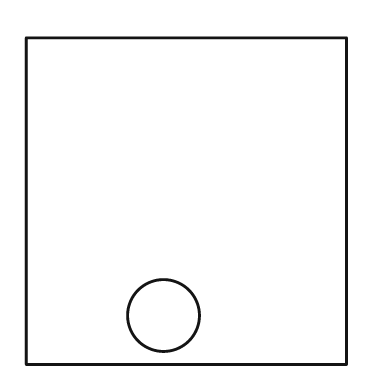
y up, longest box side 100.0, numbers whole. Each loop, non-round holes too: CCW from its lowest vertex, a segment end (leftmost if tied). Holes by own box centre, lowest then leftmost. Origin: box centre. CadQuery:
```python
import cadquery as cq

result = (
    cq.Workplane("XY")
    .moveTo(-49.0, -50.0)
    .lineTo(49.0, -50.0)
    .lineTo(49.0, 50.0)
    .lineTo(-49.0, 50.0)
    .close()
    .moveTo(-7.0, -35.0)
    .circle(11.0)
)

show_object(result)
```